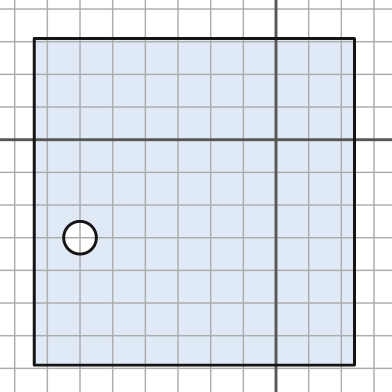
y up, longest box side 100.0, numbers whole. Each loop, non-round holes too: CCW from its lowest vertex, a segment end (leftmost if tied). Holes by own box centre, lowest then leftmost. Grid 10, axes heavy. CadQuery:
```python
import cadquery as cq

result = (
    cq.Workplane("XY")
    .moveTo(-74.0, -69.0)
    .lineTo(24.0, -69.0)
    .lineTo(24.0, 31.0)
    .lineTo(-74.0, 31.0)
    .close()
    .moveTo(-60.0, -30.0)
    .circle(5.0)
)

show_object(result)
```